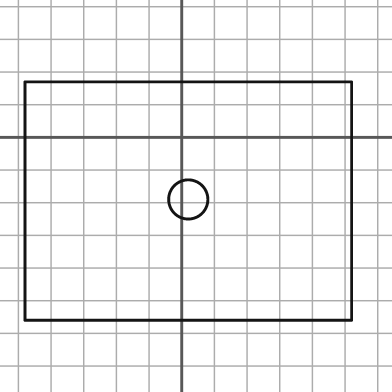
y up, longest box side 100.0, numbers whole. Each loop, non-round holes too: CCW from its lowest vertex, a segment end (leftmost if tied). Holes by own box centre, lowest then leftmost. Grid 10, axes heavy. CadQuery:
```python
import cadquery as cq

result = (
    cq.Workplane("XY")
    .moveTo(-48.0, -56.0)
    .lineTo(52.0, -56.0)
    .lineTo(52.0, 17.0)
    .lineTo(-48.0, 17.0)
    .close()
    .moveTo(2.0, -19.0)
    .circle(6.0)
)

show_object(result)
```